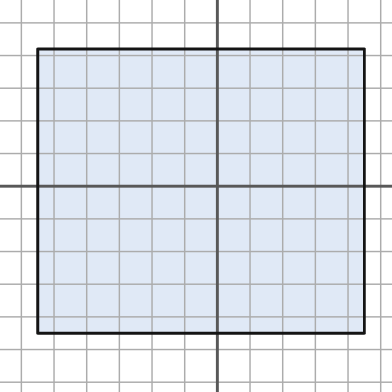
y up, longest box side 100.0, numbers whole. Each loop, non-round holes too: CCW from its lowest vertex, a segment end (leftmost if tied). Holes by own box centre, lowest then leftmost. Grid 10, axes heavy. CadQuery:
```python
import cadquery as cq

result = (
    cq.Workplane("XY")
    .moveTo(-55.0, -45.0)
    .lineTo(45.0, -45.0)
    .lineTo(45.0, 42.0)
    .lineTo(-55.0, 42.0)
    .close()
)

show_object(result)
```